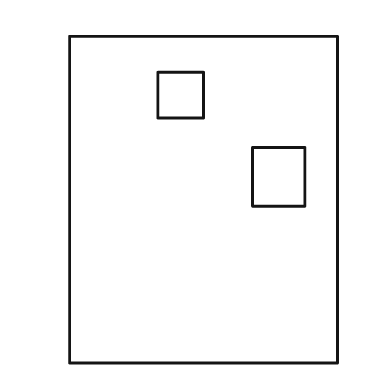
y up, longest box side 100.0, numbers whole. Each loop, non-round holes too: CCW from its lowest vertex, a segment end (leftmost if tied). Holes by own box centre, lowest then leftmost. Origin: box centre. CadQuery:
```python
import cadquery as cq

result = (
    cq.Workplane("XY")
    .moveTo(-41.0, -50.0)
    .lineTo(41.0, -50.0)
    .lineTo(41.0, 50.0)
    .lineTo(-41.0, 50.0)
    .close()
    .moveTo(15.0, -2.0)
    .lineTo(31.0, -2.0)
    .lineTo(31.0, 16.0)
    .lineTo(15.0, 16.0)
    .close()
    .moveTo(-14.0, 25.0)
    .lineTo(0.0, 25.0)
    .lineTo(0.0, 39.0)
    .lineTo(-14.0, 39.0)
    .close()
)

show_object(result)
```